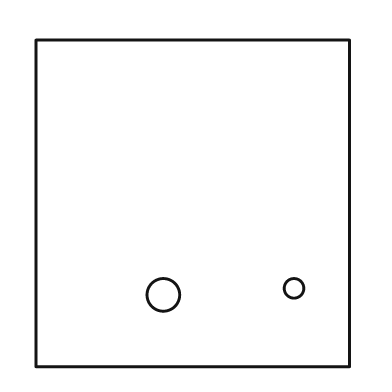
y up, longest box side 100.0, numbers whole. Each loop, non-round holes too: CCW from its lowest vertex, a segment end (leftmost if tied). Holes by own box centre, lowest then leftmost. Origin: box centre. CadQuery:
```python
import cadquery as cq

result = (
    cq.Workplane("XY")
    .moveTo(-48.0, -50.0)
    .lineTo(48.0, -50.0)
    .lineTo(48.0, 50.0)
    .lineTo(-48.0, 50.0)
    .close()
    .moveTo(-9.0, -28.0)
    .circle(5.0)
    .moveTo(31.0, -26.0)
    .circle(3.0)
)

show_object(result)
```